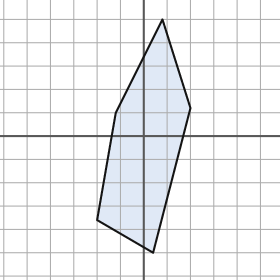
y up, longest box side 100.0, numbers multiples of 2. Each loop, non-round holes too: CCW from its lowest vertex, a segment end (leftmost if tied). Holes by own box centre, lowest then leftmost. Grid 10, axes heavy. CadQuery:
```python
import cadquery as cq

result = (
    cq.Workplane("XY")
    .moveTo(4.0, -50.0)
    .lineTo(20.0, 12.0)
    .lineTo(8.0, 50.0)
    .lineTo(-12.0, 10.0)
    .lineTo(-20.0, -36.0)
    .close()
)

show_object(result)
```